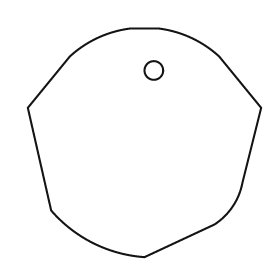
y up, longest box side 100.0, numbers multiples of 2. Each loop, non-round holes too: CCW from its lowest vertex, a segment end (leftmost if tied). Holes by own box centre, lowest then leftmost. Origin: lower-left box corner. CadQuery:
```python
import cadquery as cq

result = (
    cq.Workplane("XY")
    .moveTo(50.0, 0.0)
    .lineTo(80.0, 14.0)
    .threePointArc((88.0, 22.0), (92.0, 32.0))
    .lineTo(100.0, 64.0)
    .lineTo(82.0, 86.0)
    .threePointArc((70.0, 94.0), (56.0, 98.0))
    .lineTo(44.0, 98.0)
    .threePointArc((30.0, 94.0), (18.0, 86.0))
    .lineTo(0.0, 64.0)
    .lineTo(10.0, 20.0)
    .threePointArc((28.0, 6.0), (50.0, 0.0))
    .close()
    .moveTo(54.0, 80.0)
    .circle(4.0)
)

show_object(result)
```